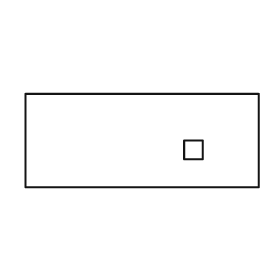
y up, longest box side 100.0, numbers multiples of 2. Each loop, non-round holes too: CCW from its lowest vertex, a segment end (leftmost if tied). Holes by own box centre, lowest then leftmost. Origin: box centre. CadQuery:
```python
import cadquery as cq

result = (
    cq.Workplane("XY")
    .moveTo(-50.0, -20.0)
    .lineTo(50.0, -20.0)
    .lineTo(50.0, 20.0)
    .lineTo(-50.0, 20.0)
    .close()
    .moveTo(18.0, -8.0)
    .lineTo(26.0, -8.0)
    .lineTo(26.0, 0.0)
    .lineTo(18.0, 0.0)
    .close()
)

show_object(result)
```